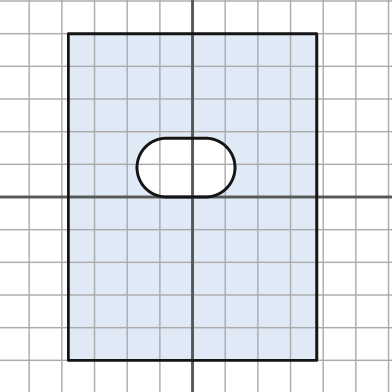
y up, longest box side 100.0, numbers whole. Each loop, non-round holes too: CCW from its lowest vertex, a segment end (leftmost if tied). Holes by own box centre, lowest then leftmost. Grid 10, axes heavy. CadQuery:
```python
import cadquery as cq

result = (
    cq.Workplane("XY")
    .moveTo(-38.0, -50.0)
    .lineTo(38.0, -50.0)
    .lineTo(38.0, 50.0)
    .lineTo(-38.0, 50.0)
    .close()
    .moveTo(-8.0, 0.0)
    .lineTo(4.0, 0.0)
    .threePointArc((13.0, 9.0), (4.0, 18.0))
    .lineTo(-8.0, 18.0)
    .threePointArc((-17.0, 9.0), (-8.0, 0.0))
    .close()
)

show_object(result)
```